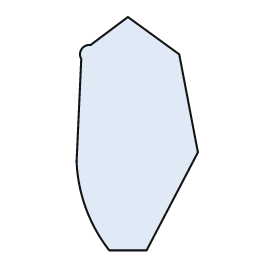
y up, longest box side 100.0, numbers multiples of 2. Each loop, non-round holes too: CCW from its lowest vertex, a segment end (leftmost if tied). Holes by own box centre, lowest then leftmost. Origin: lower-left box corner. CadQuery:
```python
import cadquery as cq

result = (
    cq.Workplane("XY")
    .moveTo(14.0, 0.0)
    .lineTo(30.0, 0.0)
    .lineTo(52.0, 42.0)
    .lineTo(44.0, 84.0)
    .lineTo(22.0, 100.0)
    .lineTo(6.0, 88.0)
    .threePointArc((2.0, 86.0), (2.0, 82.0))
    .lineTo(0.0, 38.0)
    .threePointArc((4.0, 18.0), (14.0, 0.0))
    .close()
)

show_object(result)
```